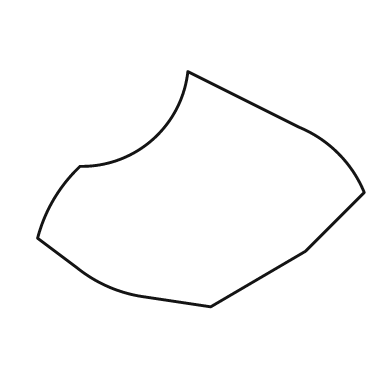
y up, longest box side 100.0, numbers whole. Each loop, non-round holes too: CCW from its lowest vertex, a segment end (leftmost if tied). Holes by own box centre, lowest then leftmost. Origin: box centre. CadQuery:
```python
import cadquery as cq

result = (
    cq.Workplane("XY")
    .moveTo(3.0, -36.0)
    .lineTo(32.0, -19.0)
    .lineTo(50.0, -1.0)
    .threePointArc((42.0, 11.0), (30.0, 19.0))
    .lineTo(-4.0, 36.0)
    .threePointArc((-15.0, 15.0), (-37.0, 7.0))
    .threePointArc((-45.0, -3.0), (-50.0, -15.0))
    .lineTo(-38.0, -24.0)
    .threePointArc((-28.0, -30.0), (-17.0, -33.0))
    .close()
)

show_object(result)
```